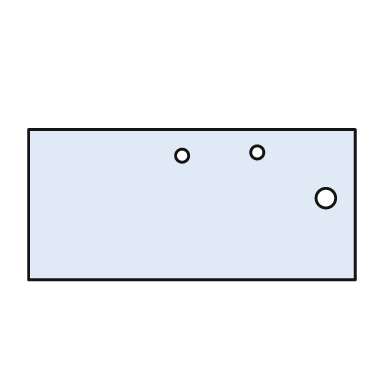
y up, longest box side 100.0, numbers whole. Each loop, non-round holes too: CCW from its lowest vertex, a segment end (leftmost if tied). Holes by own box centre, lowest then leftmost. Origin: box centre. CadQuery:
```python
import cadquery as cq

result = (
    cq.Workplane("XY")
    .moveTo(-50.0, -23.0)
    .lineTo(50.0, -23.0)
    .lineTo(50.0, 23.0)
    .lineTo(-50.0, 23.0)
    .close()
    .moveTo(41.0, 2.0)
    .circle(3.0)
    .moveTo(-3.0, 15.0)
    .circle(2.0)
    .moveTo(20.0, 16.0)
    .circle(2.0)
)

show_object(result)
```